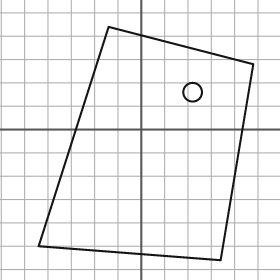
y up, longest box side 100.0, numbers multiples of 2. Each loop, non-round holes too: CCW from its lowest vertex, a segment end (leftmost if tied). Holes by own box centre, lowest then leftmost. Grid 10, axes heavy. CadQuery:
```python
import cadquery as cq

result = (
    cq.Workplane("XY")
    .moveTo(34.0, -56.0)
    .lineTo(48.0, 28.0)
    .lineTo(-14.0, 44.0)
    .lineTo(-44.0, -50.0)
    .close()
    .moveTo(22.0, 16.0)
    .circle(4.0)
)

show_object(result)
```